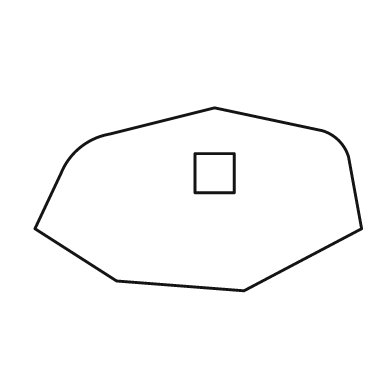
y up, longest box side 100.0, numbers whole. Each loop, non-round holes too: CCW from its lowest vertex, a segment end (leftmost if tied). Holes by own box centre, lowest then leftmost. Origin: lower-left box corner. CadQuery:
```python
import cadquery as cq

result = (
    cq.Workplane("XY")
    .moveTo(64.0, 0.0)
    .lineTo(100.0, 19.0)
    .lineTo(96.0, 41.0)
    .threePointArc((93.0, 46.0), (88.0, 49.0))
    .lineTo(55.0, 56.0)
    .lineTo(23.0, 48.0)
    .threePointArc((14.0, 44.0), (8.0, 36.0))
    .lineTo(0.0, 19.0)
    .lineTo(25.0, 3.0)
    .close()
    .moveTo(49.0, 30.0)
    .lineTo(61.0, 30.0)
    .lineTo(61.0, 42.0)
    .lineTo(49.0, 42.0)
    .close()
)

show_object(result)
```